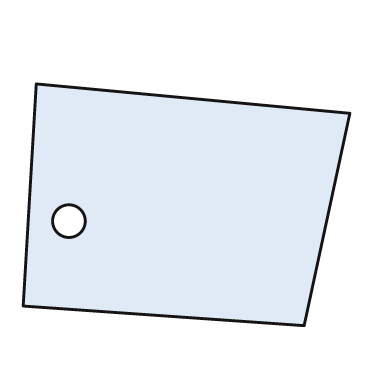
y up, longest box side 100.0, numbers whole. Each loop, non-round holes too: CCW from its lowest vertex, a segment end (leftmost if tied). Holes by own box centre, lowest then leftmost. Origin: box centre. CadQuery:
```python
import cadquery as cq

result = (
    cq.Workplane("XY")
    .moveTo(36.0, -37.0)
    .lineTo(50.0, 28.0)
    .lineTo(-46.0, 37.0)
    .lineTo(-50.0, -31.0)
    .close()
    .moveTo(-36.0, -5.0)
    .circle(5.0)
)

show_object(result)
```